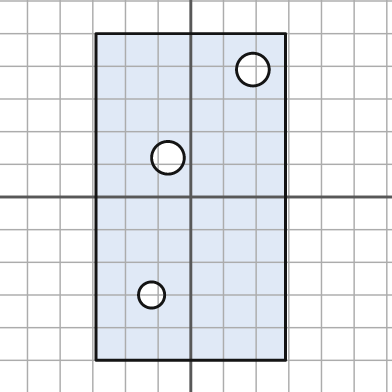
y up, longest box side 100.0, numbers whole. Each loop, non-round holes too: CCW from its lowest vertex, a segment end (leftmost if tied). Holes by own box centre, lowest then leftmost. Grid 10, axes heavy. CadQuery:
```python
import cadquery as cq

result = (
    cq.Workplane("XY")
    .moveTo(-29.0, -50.0)
    .lineTo(29.0, -50.0)
    .lineTo(29.0, 50.0)
    .lineTo(-29.0, 50.0)
    .close()
    .moveTo(-12.0, -30.0)
    .circle(4.0)
    .moveTo(-7.0, 12.0)
    .circle(5.0)
    .moveTo(19.0, 39.0)
    .circle(5.0)
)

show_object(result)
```